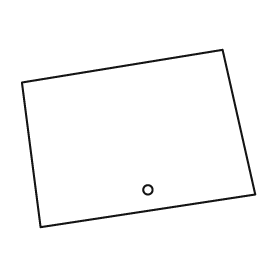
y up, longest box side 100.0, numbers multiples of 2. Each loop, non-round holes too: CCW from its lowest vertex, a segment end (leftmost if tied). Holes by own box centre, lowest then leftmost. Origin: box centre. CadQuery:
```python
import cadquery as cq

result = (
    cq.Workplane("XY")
    .moveTo(-42.0, -38.0)
    .lineTo(50.0, -24.0)
    .lineTo(36.0, 38.0)
    .lineTo(-50.0, 24.0)
    .close()
    .moveTo(4.0, -22.0)
    .circle(2.0)
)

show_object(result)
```